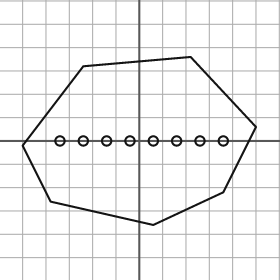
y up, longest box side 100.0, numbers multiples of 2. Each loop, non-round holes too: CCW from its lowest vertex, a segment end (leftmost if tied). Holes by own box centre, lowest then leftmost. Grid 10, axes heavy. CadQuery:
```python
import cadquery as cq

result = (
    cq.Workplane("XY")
    .moveTo(6.0, -36.0)
    .lineTo(36.0, -22.0)
    .lineTo(50.0, 6.0)
    .lineTo(22.0, 36.0)
    .lineTo(-24.0, 32.0)
    .lineTo(-50.0, -2.0)
    .lineTo(-38.0, -26.0)
    .close()
    .moveTo(-34.0, 0.0)
    .circle(2.0)
    .moveTo(-24.0, 0.0)
    .circle(2.0)
    .moveTo(-14.0, 0.0)
    .circle(2.0)
    .moveTo(-4.0, 0.0)
    .circle(2.0)
    .moveTo(6.0, 0.0)
    .circle(2.0)
    .moveTo(16.0, 0.0)
    .circle(2.0)
    .moveTo(26.0, 0.0)
    .circle(2.0)
    .moveTo(36.0, 0.0)
    .circle(2.0)
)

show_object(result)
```